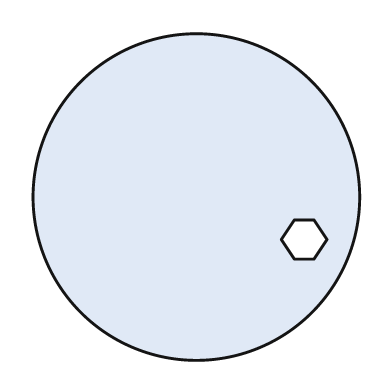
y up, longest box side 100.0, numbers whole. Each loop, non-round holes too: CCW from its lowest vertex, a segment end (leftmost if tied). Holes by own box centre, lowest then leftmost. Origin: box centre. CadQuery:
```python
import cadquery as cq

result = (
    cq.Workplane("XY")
    .moveTo(0.0, 0.0)
    .circle(50.0)
    .moveTo(30.0, -19.0)
    .lineTo(36.0, -19.0)
    .lineTo(40.0, -13.0)
    .lineTo(36.0, -7.0)
    .lineTo(30.0, -7.0)
    .lineTo(26.0, -13.0)
    .close()
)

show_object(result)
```